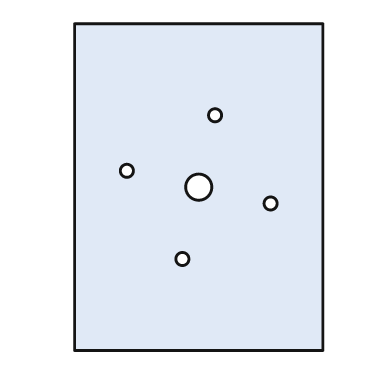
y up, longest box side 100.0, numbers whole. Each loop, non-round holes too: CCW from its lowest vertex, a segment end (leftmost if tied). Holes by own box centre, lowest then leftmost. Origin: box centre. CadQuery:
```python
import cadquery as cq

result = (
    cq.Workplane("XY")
    .moveTo(-38.0, -50.0)
    .lineTo(38.0, -50.0)
    .lineTo(38.0, 50.0)
    .lineTo(-38.0, 50.0)
    .close()
    .moveTo(-5.0, -22.0)
    .circle(2.0)
    .moveTo(22.0, -5.0)
    .circle(2.0)
    .moveTo(0.0, 0.0)
    .circle(4.0)
    .moveTo(-22.0, 5.0)
    .circle(2.0)
    .moveTo(5.0, 22.0)
    .circle(2.0)
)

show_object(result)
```